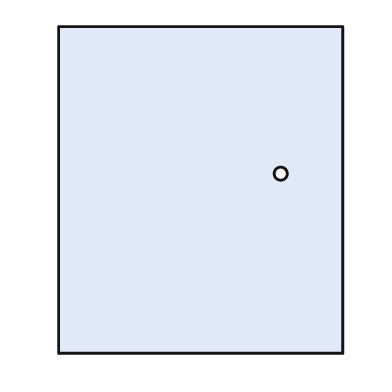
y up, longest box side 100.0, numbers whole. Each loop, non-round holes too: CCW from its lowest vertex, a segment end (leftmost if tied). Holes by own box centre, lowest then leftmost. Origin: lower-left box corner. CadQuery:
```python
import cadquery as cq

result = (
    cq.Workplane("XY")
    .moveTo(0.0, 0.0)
    .lineTo(87.0, 0.0)
    .lineTo(87.0, 100.0)
    .lineTo(0.0, 100.0)
    .close()
    .moveTo(68.0, 55.0)
    .circle(2.0)
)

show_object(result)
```